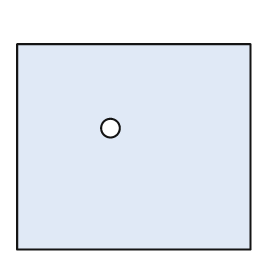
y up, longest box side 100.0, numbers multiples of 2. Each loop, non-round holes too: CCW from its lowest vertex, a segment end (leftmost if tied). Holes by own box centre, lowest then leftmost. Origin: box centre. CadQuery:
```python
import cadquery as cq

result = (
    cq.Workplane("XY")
    .moveTo(-50.0, -44.0)
    .lineTo(50.0, -44.0)
    .lineTo(50.0, 44.0)
    .lineTo(-50.0, 44.0)
    .close()
    .moveTo(-10.0, 8.0)
    .circle(4.0)
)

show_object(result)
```